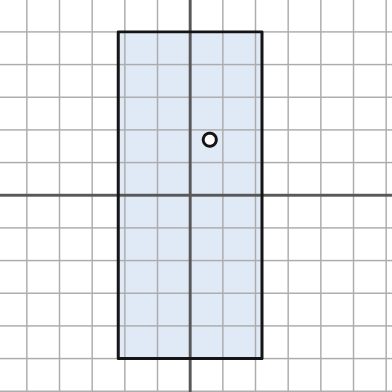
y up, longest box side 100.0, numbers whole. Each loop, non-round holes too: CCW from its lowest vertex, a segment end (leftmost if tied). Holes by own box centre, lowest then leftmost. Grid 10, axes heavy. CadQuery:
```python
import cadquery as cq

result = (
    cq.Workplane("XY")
    .moveTo(-22.0, -50.0)
    .lineTo(22.0, -50.0)
    .lineTo(22.0, 50.0)
    .lineTo(-22.0, 50.0)
    .close()
    .moveTo(6.0, 17.0)
    .circle(2.0)
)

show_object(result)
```